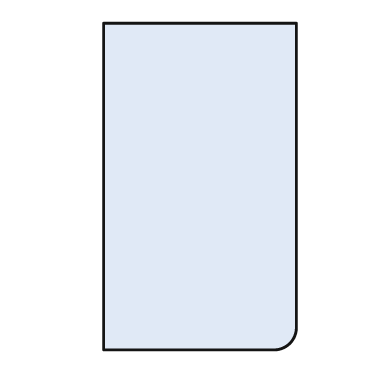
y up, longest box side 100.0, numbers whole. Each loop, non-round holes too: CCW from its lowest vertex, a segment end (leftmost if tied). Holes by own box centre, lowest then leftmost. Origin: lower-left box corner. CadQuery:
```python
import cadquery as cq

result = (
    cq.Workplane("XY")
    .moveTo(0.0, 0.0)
    .lineTo(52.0, 0.0)
    .threePointArc((57.0, 2.0), (59.0, 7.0))
    .lineTo(59.0, 100.0)
    .lineTo(0.0, 100.0)
    .close()
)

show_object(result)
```